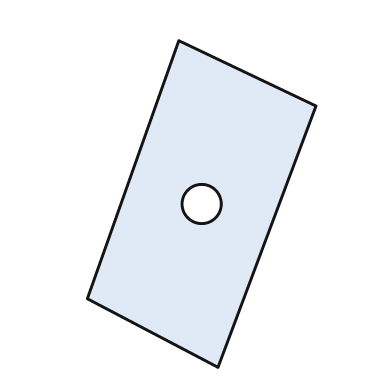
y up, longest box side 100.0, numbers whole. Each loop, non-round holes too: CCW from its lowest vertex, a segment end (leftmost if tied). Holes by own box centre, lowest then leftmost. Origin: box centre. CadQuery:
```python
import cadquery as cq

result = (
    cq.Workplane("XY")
    .moveTo(5.0, -50.0)
    .lineTo(35.0, 30.0)
    .lineTo(-7.0, 50.0)
    .lineTo(-35.0, -29.0)
    .close()
    .moveTo(0.0, 0.0)
    .circle(6.0)
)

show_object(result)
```